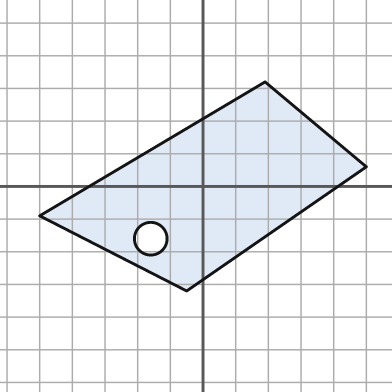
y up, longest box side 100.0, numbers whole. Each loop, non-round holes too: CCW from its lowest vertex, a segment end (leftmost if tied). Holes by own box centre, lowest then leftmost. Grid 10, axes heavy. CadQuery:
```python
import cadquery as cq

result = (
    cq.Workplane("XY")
    .moveTo(-5.0, -32.0)
    .lineTo(50.0, 6.0)
    .lineTo(19.0, 32.0)
    .lineTo(-50.0, -9.0)
    .close()
    .moveTo(-16.0, -16.0)
    .circle(5.0)
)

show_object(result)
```